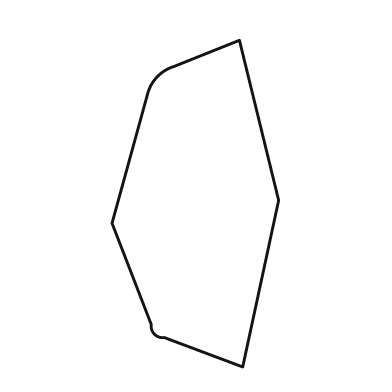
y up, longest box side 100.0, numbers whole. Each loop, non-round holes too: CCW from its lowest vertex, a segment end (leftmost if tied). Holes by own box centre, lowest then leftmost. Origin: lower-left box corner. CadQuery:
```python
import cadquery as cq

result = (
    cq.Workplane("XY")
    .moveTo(40.0, 0.0)
    .lineTo(51.0, 51.0)
    .lineTo(39.0, 100.0)
    .lineTo(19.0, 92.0)
    .threePointArc((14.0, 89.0), (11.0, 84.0))
    .lineTo(0.0, 44.0)
    .lineTo(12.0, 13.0)
    .threePointArc((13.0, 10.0), (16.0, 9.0))
    .close()
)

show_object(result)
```